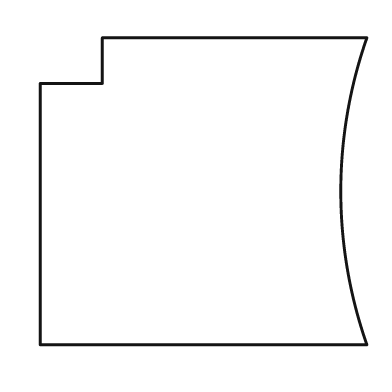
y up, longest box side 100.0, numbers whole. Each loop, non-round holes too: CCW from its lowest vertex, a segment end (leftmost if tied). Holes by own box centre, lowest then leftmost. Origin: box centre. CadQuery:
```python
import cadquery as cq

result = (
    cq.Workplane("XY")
    .moveTo(-50.0, -47.0)
    .lineTo(50.0, -47.0)
    .threePointArc((42.0, 0.0), (50.0, 47.0))
    .lineTo(-31.0, 47.0)
    .lineTo(-31.0, 33.0)
    .lineTo(-50.0, 33.0)
    .close()
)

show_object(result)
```